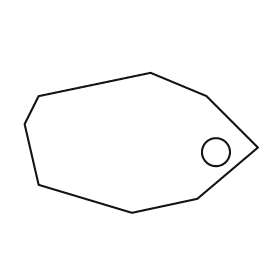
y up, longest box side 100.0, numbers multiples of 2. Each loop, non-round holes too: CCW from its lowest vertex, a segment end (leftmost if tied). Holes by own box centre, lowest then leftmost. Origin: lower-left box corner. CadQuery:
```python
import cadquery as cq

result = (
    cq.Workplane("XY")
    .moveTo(46.0, 0.0)
    .lineTo(74.0, 6.0)
    .lineTo(100.0, 28.0)
    .lineTo(78.0, 50.0)
    .lineTo(54.0, 60.0)
    .lineTo(6.0, 50.0)
    .lineTo(0.0, 38.0)
    .lineTo(6.0, 12.0)
    .close()
    .moveTo(82.0, 26.0)
    .circle(6.0)
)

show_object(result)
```